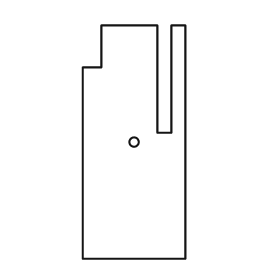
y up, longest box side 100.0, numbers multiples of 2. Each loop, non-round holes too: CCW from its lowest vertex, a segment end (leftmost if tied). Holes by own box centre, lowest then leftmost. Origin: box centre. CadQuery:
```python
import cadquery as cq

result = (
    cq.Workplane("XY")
    .moveTo(-22.0, -50.0)
    .lineTo(22.0, -50.0)
    .lineTo(22.0, 50.0)
    .lineTo(16.0, 50.0)
    .lineTo(16.0, 4.0)
    .lineTo(10.0, 4.0)
    .lineTo(10.0, 50.0)
    .lineTo(-14.0, 50.0)
    .lineTo(-14.0, 32.0)
    .lineTo(-22.0, 32.0)
    .close()
    .moveTo(0.0, 0.0)
    .circle(2.0)
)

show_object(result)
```